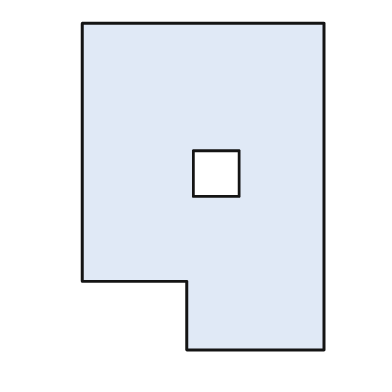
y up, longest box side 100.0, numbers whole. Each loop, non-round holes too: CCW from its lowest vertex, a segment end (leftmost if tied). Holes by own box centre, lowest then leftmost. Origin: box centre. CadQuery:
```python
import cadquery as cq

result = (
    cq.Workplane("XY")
    .moveTo(-5.0, -50.0)
    .lineTo(37.0, -50.0)
    .lineTo(37.0, 50.0)
    .lineTo(-37.0, 50.0)
    .lineTo(-37.0, -29.0)
    .lineTo(-5.0, -29.0)
    .close()
    .moveTo(-3.0, -3.0)
    .lineTo(11.0, -3.0)
    .lineTo(11.0, 11.0)
    .lineTo(-3.0, 11.0)
    .close()
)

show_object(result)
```